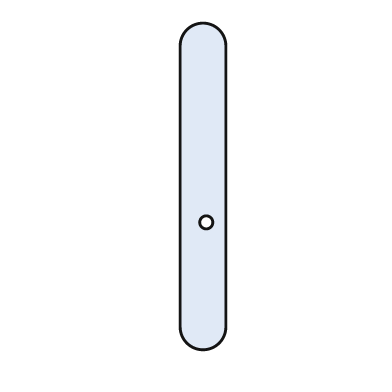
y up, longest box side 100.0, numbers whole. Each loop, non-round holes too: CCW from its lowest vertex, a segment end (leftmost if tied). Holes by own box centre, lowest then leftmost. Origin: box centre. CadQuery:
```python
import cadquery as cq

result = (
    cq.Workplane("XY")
    .moveTo(-7.0, -43.0)
    .threePointArc((0.0, -50.0), (7.0, -43.0))
    .lineTo(7.0, 43.0)
    .threePointArc((0.0, 50.0), (-7.0, 43.0))
    .close()
    .moveTo(1.0, -11.0)
    .circle(2.0)
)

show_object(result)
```